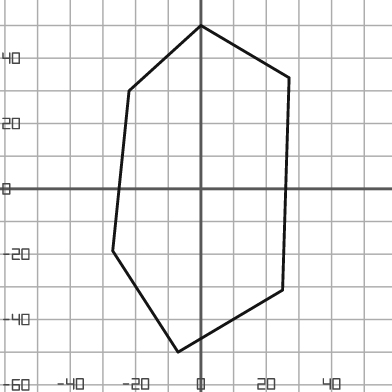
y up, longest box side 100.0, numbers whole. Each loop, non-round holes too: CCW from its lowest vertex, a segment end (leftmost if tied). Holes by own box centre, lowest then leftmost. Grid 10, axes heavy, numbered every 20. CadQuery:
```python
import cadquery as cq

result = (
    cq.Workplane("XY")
    .moveTo(-7.0, -50.0)
    .lineTo(25.0, -31.0)
    .lineTo(27.0, 34.0)
    .lineTo(0.0, 50.0)
    .lineTo(-22.0, 30.0)
    .lineTo(-27.0, -19.0)
    .close()
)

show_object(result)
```